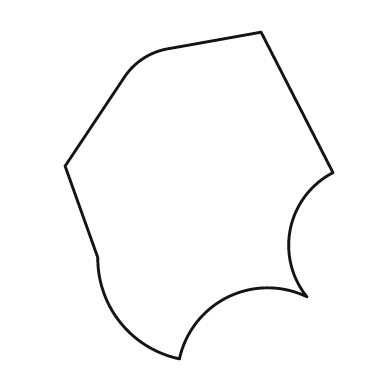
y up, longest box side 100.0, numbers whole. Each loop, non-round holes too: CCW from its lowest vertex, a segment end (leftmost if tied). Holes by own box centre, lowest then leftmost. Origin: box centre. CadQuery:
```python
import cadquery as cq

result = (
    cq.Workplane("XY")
    .moveTo(-6.0, -50.0)
    .threePointArc((9.0, -31.0), (33.0, -31.0))
    .threePointArc((28.0, -10.0), (41.0, 7.0))
    .lineTo(19.0, 50.0)
    .lineTo(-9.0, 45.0)
    .threePointArc((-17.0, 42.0), (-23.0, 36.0))
    .lineTo(-41.0, 9.0)
    .lineTo(-31.0, -19.0)
    .threePointArc((-24.0, -39.0), (-6.0, -50.0))
    .close()
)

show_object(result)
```